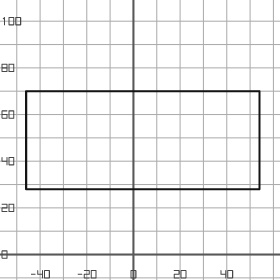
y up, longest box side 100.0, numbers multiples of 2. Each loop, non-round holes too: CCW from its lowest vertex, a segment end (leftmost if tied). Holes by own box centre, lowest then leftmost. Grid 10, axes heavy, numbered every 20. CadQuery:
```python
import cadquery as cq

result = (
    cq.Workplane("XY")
    .moveTo(-46.0, 28.0)
    .lineTo(54.0, 28.0)
    .lineTo(54.0, 70.0)
    .lineTo(-46.0, 70.0)
    .close()
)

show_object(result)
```